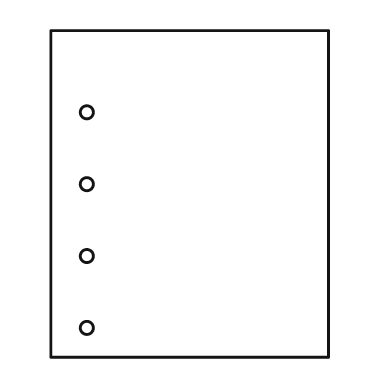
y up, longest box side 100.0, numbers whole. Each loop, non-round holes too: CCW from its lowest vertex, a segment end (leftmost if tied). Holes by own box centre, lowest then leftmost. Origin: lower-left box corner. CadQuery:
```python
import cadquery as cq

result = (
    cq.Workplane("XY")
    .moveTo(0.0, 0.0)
    .lineTo(85.0, 0.0)
    .lineTo(85.0, 100.0)
    .lineTo(0.0, 100.0)
    .close()
    .moveTo(11.0, 9.0)
    .circle(2.0)
    .moveTo(11.0, 31.0)
    .circle(2.0)
    .moveTo(11.0, 53.0)
    .circle(2.0)
    .moveTo(11.0, 75.0)
    .circle(2.0)
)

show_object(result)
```